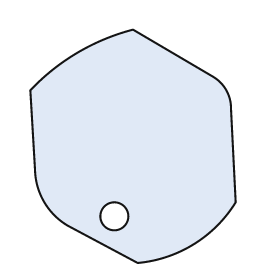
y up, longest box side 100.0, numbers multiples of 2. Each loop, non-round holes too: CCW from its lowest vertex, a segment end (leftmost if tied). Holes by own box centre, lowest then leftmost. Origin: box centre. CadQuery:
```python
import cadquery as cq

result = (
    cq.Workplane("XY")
    .moveTo(2.0, -50.0)
    .threePointArc((26.0, -42.0), (44.0, -24.0))
    .lineTo(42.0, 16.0)
    .threePointArc((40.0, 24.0), (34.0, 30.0))
    .lineTo(0.0, 50.0)
    .threePointArc((-24.0, 40.0), (-44.0, 24.0))
    .lineTo(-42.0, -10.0)
    .threePointArc((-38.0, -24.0), (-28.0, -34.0))
    .close()
    .moveTo(-8.0, -30.0)
    .circle(6.0)
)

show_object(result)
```